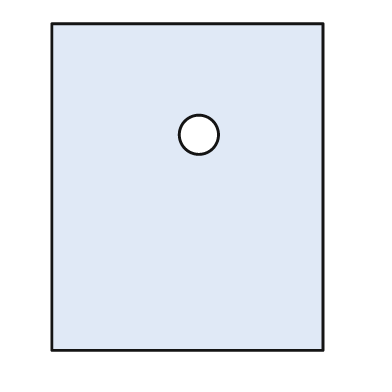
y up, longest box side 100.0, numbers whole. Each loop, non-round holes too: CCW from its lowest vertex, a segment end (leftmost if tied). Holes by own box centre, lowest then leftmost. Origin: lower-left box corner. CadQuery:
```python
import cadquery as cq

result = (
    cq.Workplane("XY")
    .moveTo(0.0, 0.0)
    .lineTo(83.0, 0.0)
    .lineTo(83.0, 100.0)
    .lineTo(0.0, 100.0)
    .close()
    .moveTo(45.0, 66.0)
    .circle(6.0)
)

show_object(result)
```